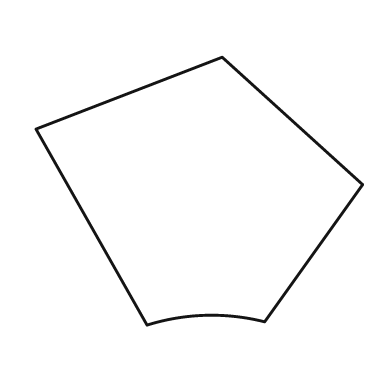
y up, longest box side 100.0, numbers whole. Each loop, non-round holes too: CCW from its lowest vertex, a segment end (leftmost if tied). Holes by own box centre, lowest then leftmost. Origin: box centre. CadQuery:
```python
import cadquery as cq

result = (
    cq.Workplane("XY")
    .moveTo(-16.0, -41.0)
    .threePointArc((2.0, -38.0), (20.0, -40.0))
    .lineTo(50.0, 2.0)
    .lineTo(7.0, 41.0)
    .lineTo(-50.0, 19.0)
    .close()
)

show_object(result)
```